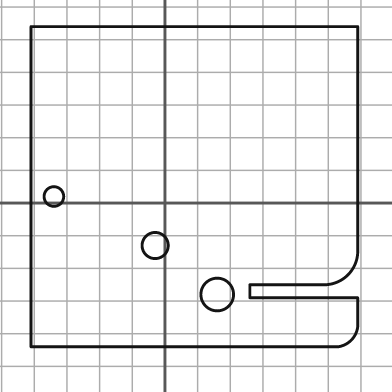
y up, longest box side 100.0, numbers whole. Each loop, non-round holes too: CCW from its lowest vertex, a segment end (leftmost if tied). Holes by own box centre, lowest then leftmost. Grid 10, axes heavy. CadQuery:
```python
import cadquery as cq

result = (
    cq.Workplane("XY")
    .moveTo(-41.0, -44.0)
    .lineTo(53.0, -44.0)
    .threePointArc((57.0, -42.0), (59.0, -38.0))
    .lineTo(59.0, -29.0)
    .lineTo(26.0, -29.0)
    .lineTo(26.0, -25.0)
    .lineTo(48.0, -25.0)
    .threePointArc((56.0, -22.0), (59.0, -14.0))
    .lineTo(59.0, 54.0)
    .lineTo(-41.0, 54.0)
    .close()
    .moveTo(16.0, -28.0)
    .circle(5.0)
    .moveTo(-3.0, -13.0)
    .circle(4.0)
    .moveTo(-34.0, 2.0)
    .circle(3.0)
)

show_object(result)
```